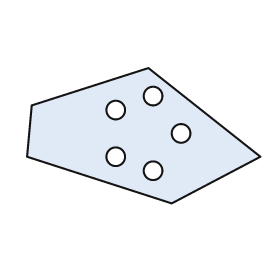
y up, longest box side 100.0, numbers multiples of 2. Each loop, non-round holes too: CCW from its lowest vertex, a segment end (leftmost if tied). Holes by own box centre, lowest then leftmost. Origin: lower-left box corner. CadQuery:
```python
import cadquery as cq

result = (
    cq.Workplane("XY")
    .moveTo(62.0, 0.0)
    .lineTo(100.0, 20.0)
    .lineTo(52.0, 58.0)
    .lineTo(2.0, 42.0)
    .lineTo(0.0, 20.0)
    .close()
    .moveTo(54.0, 14.0)
    .circle(4.0)
    .moveTo(38.0, 20.0)
    .circle(4.0)
    .moveTo(66.0, 30.0)
    .circle(4.0)
    .moveTo(38.0, 40.0)
    .circle(4.0)
    .moveTo(54.0, 46.0)
    .circle(4.0)
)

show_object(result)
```